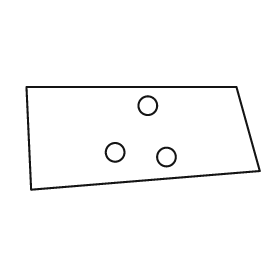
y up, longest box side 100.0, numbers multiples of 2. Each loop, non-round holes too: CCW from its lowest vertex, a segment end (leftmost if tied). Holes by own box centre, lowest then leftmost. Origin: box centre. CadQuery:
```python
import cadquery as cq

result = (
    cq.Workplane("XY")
    .moveTo(-48.0, -22.0)
    .lineTo(50.0, -14.0)
    .lineTo(40.0, 22.0)
    .lineTo(-50.0, 22.0)
    .close()
    .moveTo(10.0, -8.0)
    .circle(4.0)
    .moveTo(-12.0, -6.0)
    .circle(4.0)
    .moveTo(2.0, 14.0)
    .circle(4.0)
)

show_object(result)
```